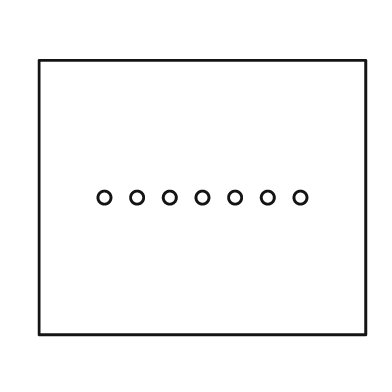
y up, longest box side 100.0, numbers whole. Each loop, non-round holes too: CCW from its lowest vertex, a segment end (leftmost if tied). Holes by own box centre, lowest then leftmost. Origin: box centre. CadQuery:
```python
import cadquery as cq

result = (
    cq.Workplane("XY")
    .moveTo(-50.0, -42.0)
    .lineTo(50.0, -42.0)
    .lineTo(50.0, 42.0)
    .lineTo(-50.0, 42.0)
    .close()
    .moveTo(-30.0, 0.0)
    .circle(2.0)
    .moveTo(-20.0, 0.0)
    .circle(2.0)
    .moveTo(-10.0, 0.0)
    .circle(2.0)
    .moveTo(0.0, 0.0)
    .circle(2.0)
    .moveTo(10.0, 0.0)
    .circle(2.0)
    .moveTo(20.0, 0.0)
    .circle(2.0)
    .moveTo(30.0, 0.0)
    .circle(2.0)
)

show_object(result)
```